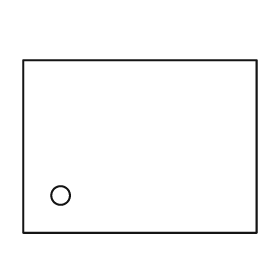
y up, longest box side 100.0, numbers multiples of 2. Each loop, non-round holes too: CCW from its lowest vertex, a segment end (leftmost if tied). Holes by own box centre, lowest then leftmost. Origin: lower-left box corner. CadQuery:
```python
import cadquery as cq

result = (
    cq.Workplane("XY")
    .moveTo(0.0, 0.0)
    .lineTo(100.0, 0.0)
    .lineTo(100.0, 74.0)
    .lineTo(0.0, 74.0)
    .close()
    .moveTo(16.0, 16.0)
    .circle(4.0)
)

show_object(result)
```